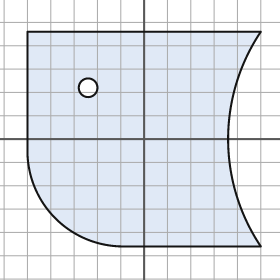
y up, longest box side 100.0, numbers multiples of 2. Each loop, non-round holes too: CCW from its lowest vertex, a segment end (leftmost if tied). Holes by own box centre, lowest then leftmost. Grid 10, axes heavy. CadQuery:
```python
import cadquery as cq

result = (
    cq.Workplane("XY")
    .moveTo(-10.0, -46.0)
    .lineTo(50.0, -46.0)
    .threePointArc((36.0, 0.0), (50.0, 46.0))
    .lineTo(-50.0, 46.0)
    .lineTo(-50.0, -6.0)
    .threePointArc((-38.0, -34.0), (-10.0, -46.0))
    .close()
    .moveTo(-24.0, 22.0)
    .circle(4.0)
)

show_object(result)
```